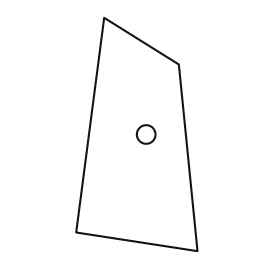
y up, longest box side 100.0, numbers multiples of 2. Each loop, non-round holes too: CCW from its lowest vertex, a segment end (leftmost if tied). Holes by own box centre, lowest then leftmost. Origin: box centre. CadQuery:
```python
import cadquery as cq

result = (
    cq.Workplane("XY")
    .moveTo(26.0, -50.0)
    .lineTo(18.0, 30.0)
    .lineTo(-14.0, 50.0)
    .lineTo(-26.0, -42.0)
    .close()
    .moveTo(4.0, 0.0)
    .circle(4.0)
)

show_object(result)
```